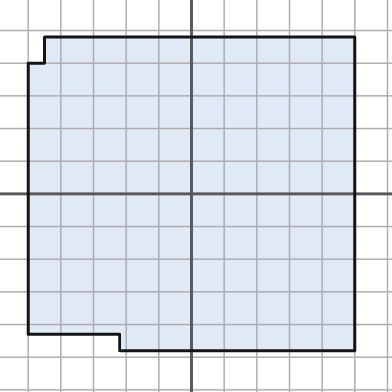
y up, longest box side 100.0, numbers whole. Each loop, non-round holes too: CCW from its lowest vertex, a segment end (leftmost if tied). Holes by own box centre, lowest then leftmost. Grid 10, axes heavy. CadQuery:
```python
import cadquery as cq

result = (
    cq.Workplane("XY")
    .moveTo(-22.0, -48.0)
    .lineTo(50.0, -48.0)
    .lineTo(50.0, 48.0)
    .lineTo(-45.0, 48.0)
    .lineTo(-45.0, 40.0)
    .lineTo(-50.0, 40.0)
    .lineTo(-50.0, -43.0)
    .lineTo(-22.0, -43.0)
    .close()
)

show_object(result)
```